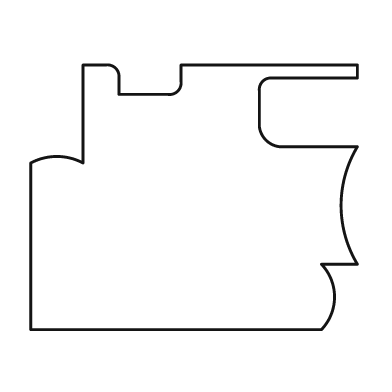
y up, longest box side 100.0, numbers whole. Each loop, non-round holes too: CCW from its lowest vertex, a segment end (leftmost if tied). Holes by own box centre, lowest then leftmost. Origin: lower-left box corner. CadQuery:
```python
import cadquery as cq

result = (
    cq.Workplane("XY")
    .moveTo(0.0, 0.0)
    .lineTo(89.0, 0.0)
    .threePointArc((93.0, 10.0), (89.0, 20.0))
    .lineTo(100.0, 20.0)
    .threePointArc((95.0, 38.0), (100.0, 56.0))
    .lineTo(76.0, 56.0)
    .threePointArc((72.0, 58.0), (70.0, 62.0))
    .lineTo(70.0, 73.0)
    .threePointArc((71.0, 76.0), (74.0, 77.0))
    .lineTo(100.0, 77.0)
    .lineTo(100.0, 81.0)
    .lineTo(46.0, 81.0)
    .lineTo(46.0, 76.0)
    .threePointArc((45.0, 73.0), (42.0, 72.0))
    .lineTo(27.0, 72.0)
    .lineTo(27.0, 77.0)
    .threePointArc((26.0, 80.0), (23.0, 81.0))
    .lineTo(16.0, 81.0)
    .lineTo(16.0, 51.0)
    .threePointArc((8.0, 53.0), (0.0, 51.0))
    .close()
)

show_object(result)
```